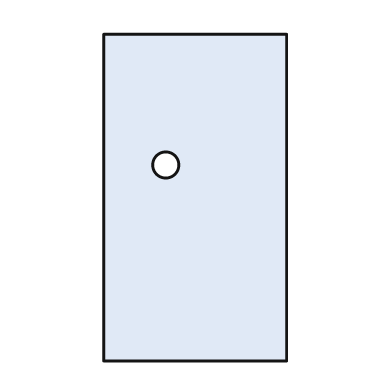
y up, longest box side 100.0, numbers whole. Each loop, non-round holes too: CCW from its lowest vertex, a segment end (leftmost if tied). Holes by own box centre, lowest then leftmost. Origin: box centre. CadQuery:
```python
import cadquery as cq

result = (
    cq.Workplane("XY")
    .moveTo(-28.0, -50.0)
    .lineTo(28.0, -50.0)
    .lineTo(28.0, 50.0)
    .lineTo(-28.0, 50.0)
    .close()
    .moveTo(-9.0, 10.0)
    .circle(4.0)
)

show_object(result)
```